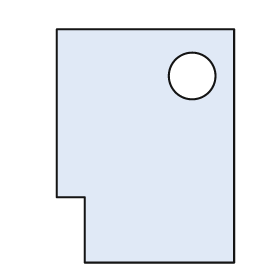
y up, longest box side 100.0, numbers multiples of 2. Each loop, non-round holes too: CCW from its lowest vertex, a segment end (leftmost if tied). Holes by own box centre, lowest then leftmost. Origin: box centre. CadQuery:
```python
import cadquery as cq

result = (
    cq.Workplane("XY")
    .moveTo(-26.0, -50.0)
    .lineTo(38.0, -50.0)
    .lineTo(38.0, 50.0)
    .lineTo(-38.0, 50.0)
    .lineTo(-38.0, -22.0)
    .lineTo(-26.0, -22.0)
    .close()
    .moveTo(20.0, 30.0)
    .circle(10.0)
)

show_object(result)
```